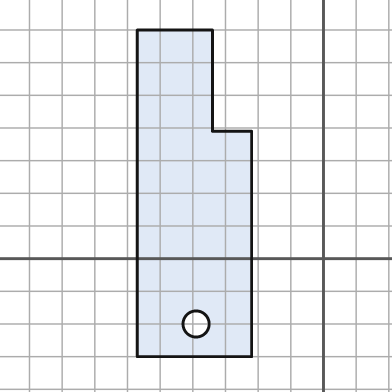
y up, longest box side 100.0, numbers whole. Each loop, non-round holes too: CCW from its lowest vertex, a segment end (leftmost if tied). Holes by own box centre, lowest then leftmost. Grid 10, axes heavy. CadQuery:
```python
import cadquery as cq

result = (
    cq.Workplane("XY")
    .moveTo(-57.0, -30.0)
    .lineTo(-22.0, -30.0)
    .lineTo(-22.0, 39.0)
    .lineTo(-34.0, 39.0)
    .lineTo(-34.0, 70.0)
    .lineTo(-57.0, 70.0)
    .close()
    .moveTo(-39.0, -20.0)
    .circle(4.0)
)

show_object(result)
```